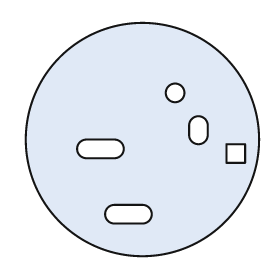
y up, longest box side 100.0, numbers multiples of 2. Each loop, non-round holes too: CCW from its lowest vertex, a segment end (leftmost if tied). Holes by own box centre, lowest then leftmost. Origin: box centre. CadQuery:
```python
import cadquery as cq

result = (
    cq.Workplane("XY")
    .moveTo(0.0, 0.0)
    .circle(50.0)
    .moveTo(-12.0, -36.0)
    .lineTo(0.0, -36.0)
    .threePointArc((4.0, -32.0), (0.0, -28.0))
    .lineTo(-12.0, -28.0)
    .threePointArc((-16.0, -32.0), (-12.0, -36.0))
    .close()
    .moveTo(36.0, -10.0)
    .lineTo(44.0, -10.0)
    .lineTo(44.0, -2.0)
    .lineTo(36.0, -2.0)
    .close()
    .moveTo(-24.0, -8.0)
    .lineTo(-12.0, -8.0)
    .threePointArc((-8.0, -4.0), (-12.0, 0.0))
    .lineTo(-24.0, 0.0)
    .threePointArc((-28.0, -4.0), (-24.0, -8.0))
    .close()
    .moveTo(20.0, 2.0)
    .threePointArc((24.0, -2.0), (28.0, 2.0))
    .lineTo(28.0, 6.0)
    .threePointArc((24.0, 10.0), (20.0, 6.0))
    .close()
    .moveTo(14.0, 20.0)
    .circle(4.0)
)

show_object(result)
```